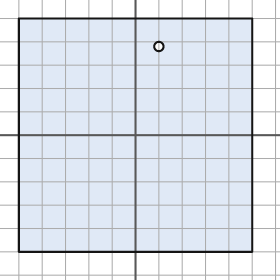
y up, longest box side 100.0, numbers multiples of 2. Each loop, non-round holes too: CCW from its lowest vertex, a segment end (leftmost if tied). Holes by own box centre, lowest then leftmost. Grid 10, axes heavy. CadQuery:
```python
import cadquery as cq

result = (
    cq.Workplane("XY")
    .moveTo(-50.0, -50.0)
    .lineTo(50.0, -50.0)
    .lineTo(50.0, 50.0)
    .lineTo(-50.0, 50.0)
    .close()
    .moveTo(10.0, 38.0)
    .circle(2.0)
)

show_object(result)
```